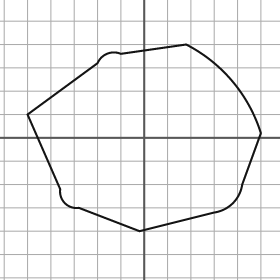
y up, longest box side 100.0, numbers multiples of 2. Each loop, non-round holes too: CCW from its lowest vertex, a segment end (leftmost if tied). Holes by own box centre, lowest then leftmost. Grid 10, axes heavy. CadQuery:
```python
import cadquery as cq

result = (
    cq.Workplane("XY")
    .moveTo(-2.0, -40.0)
    .lineTo(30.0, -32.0)
    .threePointArc((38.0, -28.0), (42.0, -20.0))
    .lineTo(50.0, 2.0)
    .threePointArc((38.0, 24.0), (18.0, 40.0))
    .lineTo(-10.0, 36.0)
    .threePointArc((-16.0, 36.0), (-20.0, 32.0))
    .lineTo(-50.0, 10.0)
    .lineTo(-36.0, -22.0)
    .threePointArc((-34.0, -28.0), (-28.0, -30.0))
    .close()
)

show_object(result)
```